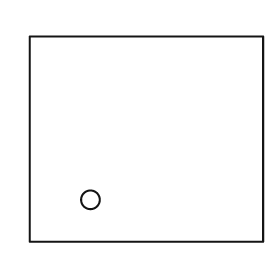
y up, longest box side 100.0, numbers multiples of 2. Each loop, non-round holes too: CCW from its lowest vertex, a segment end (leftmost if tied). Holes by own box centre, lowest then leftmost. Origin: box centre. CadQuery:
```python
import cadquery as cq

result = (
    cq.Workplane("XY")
    .moveTo(-50.0, -44.0)
    .lineTo(50.0, -44.0)
    .lineTo(50.0, 44.0)
    .lineTo(-50.0, 44.0)
    .close()
    .moveTo(-24.0, -26.0)
    .circle(4.0)
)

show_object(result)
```